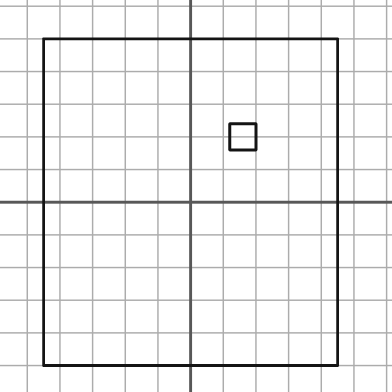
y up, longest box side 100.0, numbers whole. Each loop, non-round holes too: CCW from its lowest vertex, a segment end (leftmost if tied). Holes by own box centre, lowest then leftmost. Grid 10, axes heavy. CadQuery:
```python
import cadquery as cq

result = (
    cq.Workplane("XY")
    .moveTo(-45.0, -50.0)
    .lineTo(45.0, -50.0)
    .lineTo(45.0, 50.0)
    .lineTo(-45.0, 50.0)
    .close()
    .moveTo(12.0, 16.0)
    .lineTo(20.0, 16.0)
    .lineTo(20.0, 24.0)
    .lineTo(12.0, 24.0)
    .close()
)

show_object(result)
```